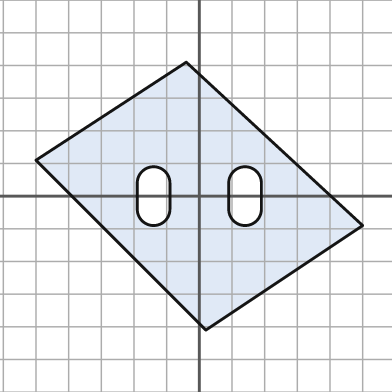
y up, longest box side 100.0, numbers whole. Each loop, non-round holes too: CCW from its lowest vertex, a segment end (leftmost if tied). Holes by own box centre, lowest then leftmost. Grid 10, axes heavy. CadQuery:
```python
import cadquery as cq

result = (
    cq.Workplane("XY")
    .moveTo(2.0, -41.0)
    .lineTo(50.0, -9.0)
    .lineTo(-4.0, 41.0)
    .lineTo(-50.0, 11.0)
    .close()
    .moveTo(-19.0, -4.0)
    .threePointArc((-14.0, -9.0), (-9.0, -4.0))
    .lineTo(-9.0, 4.0)
    .threePointArc((-14.0, 9.0), (-19.0, 4.0))
    .close()
    .moveTo(9.0, -4.0)
    .threePointArc((14.0, -9.0), (19.0, -4.0))
    .lineTo(19.0, 4.0)
    .threePointArc((14.0, 9.0), (9.0, 4.0))
    .close()
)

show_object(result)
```